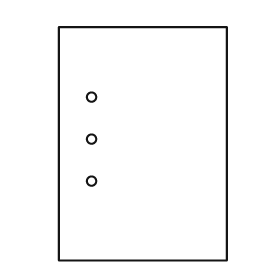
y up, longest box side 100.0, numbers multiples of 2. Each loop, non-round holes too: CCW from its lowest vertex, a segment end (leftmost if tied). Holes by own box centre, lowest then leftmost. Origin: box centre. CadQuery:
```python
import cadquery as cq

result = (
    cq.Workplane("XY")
    .moveTo(-36.0, -50.0)
    .lineTo(36.0, -50.0)
    .lineTo(36.0, 50.0)
    .lineTo(-36.0, 50.0)
    .close()
    .moveTo(-22.0, -16.0)
    .circle(2.0)
    .moveTo(-22.0, 2.0)
    .circle(2.0)
    .moveTo(-22.0, 20.0)
    .circle(2.0)
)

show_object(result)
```